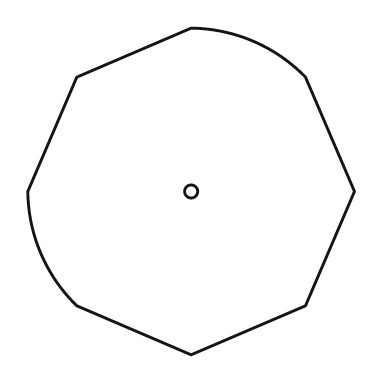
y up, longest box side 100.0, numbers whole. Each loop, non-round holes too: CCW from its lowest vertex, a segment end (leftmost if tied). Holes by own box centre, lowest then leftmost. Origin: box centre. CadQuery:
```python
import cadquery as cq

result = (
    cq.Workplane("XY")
    .moveTo(0.0, -50.0)
    .lineTo(35.0, -35.0)
    .lineTo(50.0, 0.0)
    .lineTo(35.0, 35.0)
    .threePointArc((19.0, 46.0), (0.0, 50.0))
    .lineTo(-35.0, 35.0)
    .lineTo(-50.0, 0.0)
    .threePointArc((-46.0, -19.0), (-35.0, -35.0))
    .close()
    .moveTo(0.0, 0.0)
    .circle(2.0)
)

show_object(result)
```